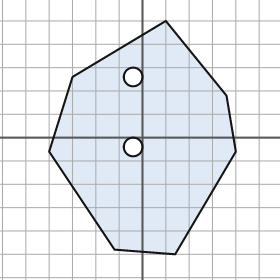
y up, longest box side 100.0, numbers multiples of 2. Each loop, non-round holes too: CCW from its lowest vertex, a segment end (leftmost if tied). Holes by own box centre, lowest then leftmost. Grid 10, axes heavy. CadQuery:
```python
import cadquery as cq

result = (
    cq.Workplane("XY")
    .moveTo(14.0, -50.0)
    .lineTo(40.0, -6.0)
    .lineTo(36.0, 18.0)
    .lineTo(10.0, 50.0)
    .lineTo(-30.0, 26.0)
    .lineTo(-40.0, -6.0)
    .lineTo(-12.0, -48.0)
    .close()
    .moveTo(-4.0, -4.0)
    .circle(4.0)
    .moveTo(-4.0, 26.0)
    .circle(4.0)
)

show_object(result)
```